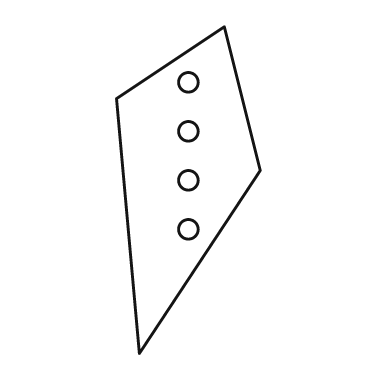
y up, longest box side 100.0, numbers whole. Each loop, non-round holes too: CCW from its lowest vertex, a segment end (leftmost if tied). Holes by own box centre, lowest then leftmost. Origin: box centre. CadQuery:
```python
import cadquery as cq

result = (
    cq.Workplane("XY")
    .moveTo(-15.0, -50.0)
    .lineTo(22.0, 6.0)
    .lineTo(11.0, 50.0)
    .lineTo(-22.0, 28.0)
    .close()
    .moveTo(0.0, -12.0)
    .circle(3.0)
    .moveTo(0.0, 3.0)
    .circle(3.0)
    .moveTo(0.0, 18.0)
    .circle(3.0)
    .moveTo(0.0, 33.0)
    .circle(3.0)
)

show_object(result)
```